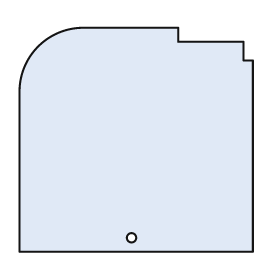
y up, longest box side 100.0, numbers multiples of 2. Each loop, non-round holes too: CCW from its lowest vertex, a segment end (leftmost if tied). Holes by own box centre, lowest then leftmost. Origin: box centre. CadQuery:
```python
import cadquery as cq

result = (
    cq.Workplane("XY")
    .moveTo(-50.0, -48.0)
    .lineTo(50.0, -48.0)
    .lineTo(50.0, 34.0)
    .lineTo(46.0, 34.0)
    .lineTo(46.0, 42.0)
    .lineTo(18.0, 42.0)
    .lineTo(18.0, 48.0)
    .lineTo(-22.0, 48.0)
    .threePointArc((-42.0, 40.0), (-50.0, 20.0))
    .close()
    .moveTo(-2.0, -42.0)
    .circle(2.0)
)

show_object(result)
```